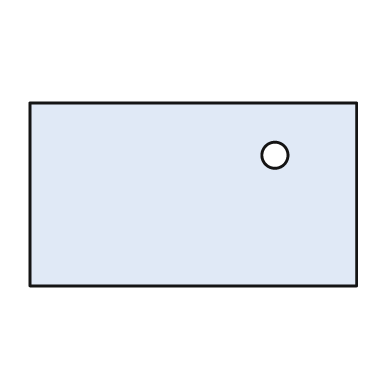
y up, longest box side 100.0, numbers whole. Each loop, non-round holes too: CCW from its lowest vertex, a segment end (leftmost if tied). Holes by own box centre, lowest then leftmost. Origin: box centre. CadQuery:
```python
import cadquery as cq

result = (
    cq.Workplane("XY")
    .moveTo(-50.0, -28.0)
    .lineTo(50.0, -28.0)
    .lineTo(50.0, 28.0)
    .lineTo(-50.0, 28.0)
    .close()
    .moveTo(25.0, 12.0)
    .circle(4.0)
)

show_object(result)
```